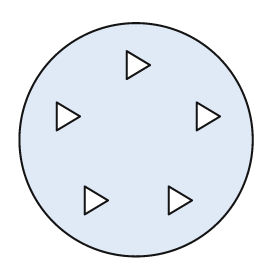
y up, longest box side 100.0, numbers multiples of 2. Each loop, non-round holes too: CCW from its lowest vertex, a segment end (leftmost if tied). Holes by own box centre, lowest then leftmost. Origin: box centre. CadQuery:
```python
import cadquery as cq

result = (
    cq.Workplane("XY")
    .moveTo(0.0, 0.0)
    .circle(50.0)
    .moveTo(-22.0, -32.0)
    .lineTo(-12.0, -26.0)
    .lineTo(-22.0, -20.0)
    .close()
    .moveTo(14.0, -32.0)
    .lineTo(24.0, -26.0)
    .lineTo(14.0, -20.0)
    .close()
    .moveTo(-34.0, 4.0)
    .lineTo(-24.0, 10.0)
    .lineTo(-34.0, 16.0)
    .close()
    .moveTo(26.0, 4.0)
    .lineTo(36.0, 10.0)
    .lineTo(26.0, 16.0)
    .close()
    .moveTo(-4.0, 26.0)
    .lineTo(6.0, 32.0)
    .lineTo(-4.0, 38.0)
    .close()
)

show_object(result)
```